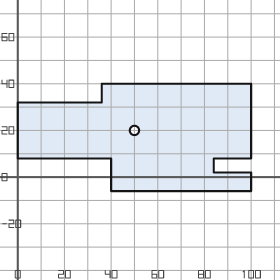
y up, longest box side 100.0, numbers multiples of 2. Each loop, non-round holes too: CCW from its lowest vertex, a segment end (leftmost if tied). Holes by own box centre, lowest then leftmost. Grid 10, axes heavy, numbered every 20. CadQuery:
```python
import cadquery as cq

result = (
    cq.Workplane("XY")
    .moveTo(40.0, -6.0)
    .lineTo(100.0, -6.0)
    .lineTo(100.0, 2.0)
    .lineTo(84.0, 2.0)
    .lineTo(84.0, 8.0)
    .lineTo(100.0, 8.0)
    .lineTo(100.0, 40.0)
    .lineTo(36.0, 40.0)
    .lineTo(36.0, 32.0)
    .lineTo(0.0, 32.0)
    .lineTo(0.0, 8.0)
    .lineTo(40.0, 8.0)
    .close()
    .moveTo(50.0, 20.0)
    .circle(2.0)
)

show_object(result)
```